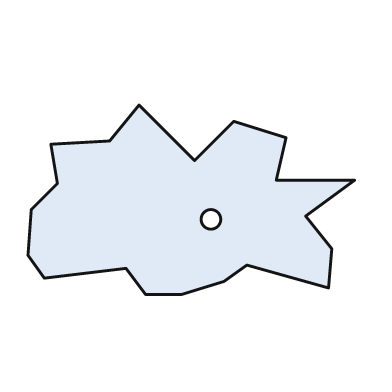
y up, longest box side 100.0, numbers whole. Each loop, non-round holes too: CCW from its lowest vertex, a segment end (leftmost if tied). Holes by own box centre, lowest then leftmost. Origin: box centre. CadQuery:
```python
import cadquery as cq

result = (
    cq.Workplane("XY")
    .moveTo(-14.0, -29.0)
    .lineTo(-3.0, -29.0)
    .lineTo(10.0, -25.0)
    .lineTo(17.0, -20.0)
    .lineTo(42.0, -27.0)
    .lineTo(43.0, -15.0)
    .lineTo(35.0, -5.0)
    .lineTo(50.0, 6.0)
    .lineTo(26.0, 6.0)
    .lineTo(29.0, 19.0)
    .lineTo(13.0, 24.0)
    .lineTo(1.0, 12.0)
    .lineTo(-16.0, 29.0)
    .lineTo(-25.0, 18.0)
    .lineTo(-43.0, 17.0)
    .lineTo(-41.0, 5.0)
    .lineTo(-49.0, -3.0)
    .lineTo(-50.0, -17.0)
    .lineTo(-45.0, -24.0)
    .lineTo(-20.0, -21.0)
    .close()
    .moveTo(6.0, -6.0)
    .circle(3.0)
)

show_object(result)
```